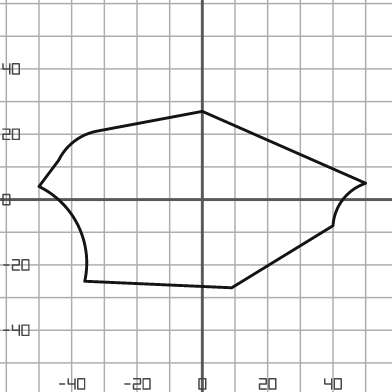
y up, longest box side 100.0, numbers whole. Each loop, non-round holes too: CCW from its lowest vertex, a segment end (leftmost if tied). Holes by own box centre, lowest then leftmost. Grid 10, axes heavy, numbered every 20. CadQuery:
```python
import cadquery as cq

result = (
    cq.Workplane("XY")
    .moveTo(9.0, -27.0)
    .lineTo(40.0, -8.0)
    .threePointArc((43.0, 0.0), (50.0, 5.0))
    .lineTo(0.0, 27.0)
    .lineTo(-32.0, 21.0)
    .threePointArc((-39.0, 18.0), (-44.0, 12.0))
    .lineTo(-50.0, 4.0)
    .threePointArc((-38.0, -8.0), (-36.0, -25.0))
    .close()
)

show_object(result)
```